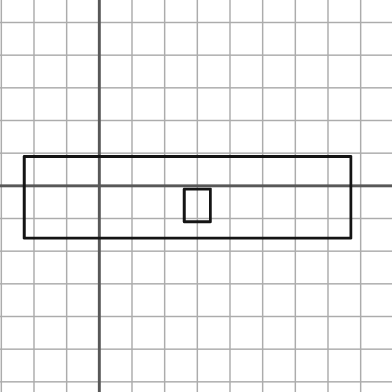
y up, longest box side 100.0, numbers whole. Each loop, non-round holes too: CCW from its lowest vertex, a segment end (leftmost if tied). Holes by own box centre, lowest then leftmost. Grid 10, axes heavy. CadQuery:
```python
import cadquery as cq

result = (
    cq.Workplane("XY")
    .moveTo(-23.0, -16.0)
    .lineTo(77.0, -16.0)
    .lineTo(77.0, 9.0)
    .lineTo(-23.0, 9.0)
    .close()
    .moveTo(26.0, -11.0)
    .lineTo(34.0, -11.0)
    .lineTo(34.0, -1.0)
    .lineTo(26.0, -1.0)
    .close()
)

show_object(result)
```